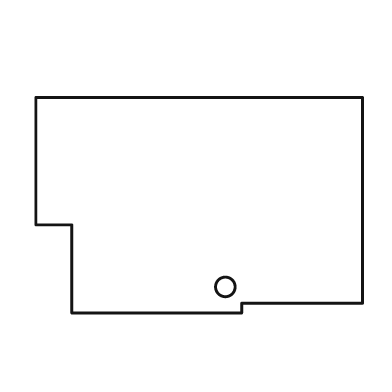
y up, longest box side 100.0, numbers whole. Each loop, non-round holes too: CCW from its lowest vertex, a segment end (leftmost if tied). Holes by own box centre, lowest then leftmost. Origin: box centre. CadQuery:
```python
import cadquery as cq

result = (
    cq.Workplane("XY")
    .moveTo(-39.0, -33.0)
    .lineTo(13.0, -33.0)
    .lineTo(13.0, -30.0)
    .lineTo(50.0, -30.0)
    .lineTo(50.0, 33.0)
    .lineTo(-50.0, 33.0)
    .lineTo(-50.0, -6.0)
    .lineTo(-39.0, -6.0)
    .close()
    .moveTo(8.0, -25.0)
    .circle(3.0)
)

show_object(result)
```